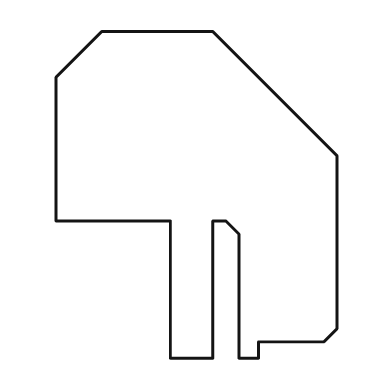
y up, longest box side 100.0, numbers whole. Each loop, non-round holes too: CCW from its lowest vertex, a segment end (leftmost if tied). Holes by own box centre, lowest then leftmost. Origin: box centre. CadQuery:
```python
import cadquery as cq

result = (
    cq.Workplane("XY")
    .moveTo(-8.0, -50.0)
    .lineTo(5.0, -50.0)
    .lineTo(5.0, -8.0)
    .lineTo(9.0, -8.0)
    .lineTo(13.0, -12.0)
    .lineTo(13.0, -50.0)
    .lineTo(19.0, -50.0)
    .lineTo(19.0, -45.0)
    .lineTo(39.0, -45.0)
    .lineTo(43.0, -41.0)
    .lineTo(43.0, 12.0)
    .lineTo(5.0, 50.0)
    .lineTo(-29.0, 50.0)
    .lineTo(-43.0, 36.0)
    .lineTo(-43.0, -8.0)
    .lineTo(-8.0, -8.0)
    .close()
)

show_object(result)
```